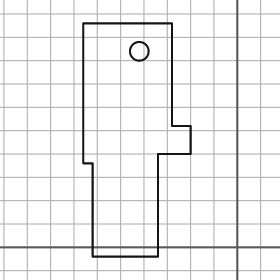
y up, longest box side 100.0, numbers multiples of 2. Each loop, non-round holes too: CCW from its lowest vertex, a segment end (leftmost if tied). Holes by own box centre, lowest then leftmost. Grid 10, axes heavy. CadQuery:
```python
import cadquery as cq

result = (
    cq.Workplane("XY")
    .moveTo(-62.0, -4.0)
    .lineTo(-34.0, -4.0)
    .lineTo(-34.0, 40.0)
    .lineTo(-20.0, 40.0)
    .lineTo(-20.0, 52.0)
    .lineTo(-28.0, 52.0)
    .lineTo(-28.0, 96.0)
    .lineTo(-66.0, 96.0)
    .lineTo(-66.0, 36.0)
    .lineTo(-62.0, 36.0)
    .close()
    .moveTo(-42.0, 84.0)
    .circle(4.0)
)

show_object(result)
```